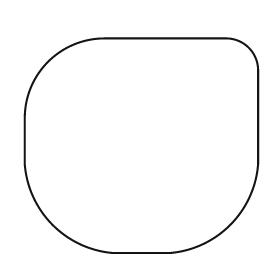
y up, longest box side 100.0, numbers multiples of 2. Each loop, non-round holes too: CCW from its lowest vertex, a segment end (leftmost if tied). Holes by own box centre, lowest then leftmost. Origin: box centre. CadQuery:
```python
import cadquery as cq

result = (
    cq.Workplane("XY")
    .moveTo(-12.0, -46.0)
    .lineTo(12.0, -46.0)
    .threePointArc((38.0, -34.0), (50.0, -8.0))
    .lineTo(50.0, 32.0)
    .threePointArc((46.0, 42.0), (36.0, 46.0))
    .lineTo(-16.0, 46.0)
    .threePointArc((-40.0, 36.0), (-50.0, 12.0))
    .lineTo(-50.0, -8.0)
    .threePointArc((-38.0, -34.0), (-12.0, -46.0))
    .close()
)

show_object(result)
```